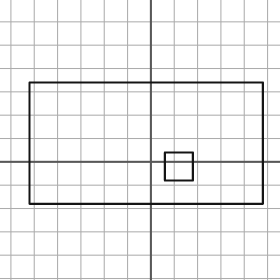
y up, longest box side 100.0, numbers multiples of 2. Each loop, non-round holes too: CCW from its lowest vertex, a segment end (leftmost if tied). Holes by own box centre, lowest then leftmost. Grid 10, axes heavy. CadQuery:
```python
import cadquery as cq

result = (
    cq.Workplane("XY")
    .moveTo(-52.0, -18.0)
    .lineTo(48.0, -18.0)
    .lineTo(48.0, 34.0)
    .lineTo(-52.0, 34.0)
    .close()
    .moveTo(6.0, -8.0)
    .lineTo(18.0, -8.0)
    .lineTo(18.0, 4.0)
    .lineTo(6.0, 4.0)
    .close()
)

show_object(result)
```